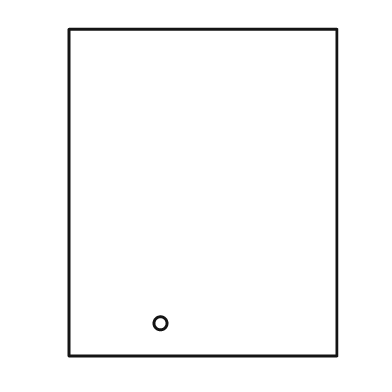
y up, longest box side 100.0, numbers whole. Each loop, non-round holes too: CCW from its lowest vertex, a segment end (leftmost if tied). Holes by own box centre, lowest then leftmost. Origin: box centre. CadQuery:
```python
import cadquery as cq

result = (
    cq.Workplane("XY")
    .moveTo(-41.0, -50.0)
    .lineTo(41.0, -50.0)
    .lineTo(41.0, 50.0)
    .lineTo(-41.0, 50.0)
    .close()
    .moveTo(-13.0, -40.0)
    .circle(2.0)
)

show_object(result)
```